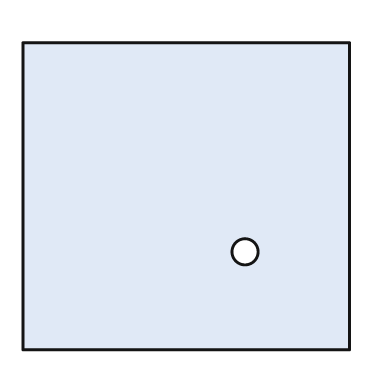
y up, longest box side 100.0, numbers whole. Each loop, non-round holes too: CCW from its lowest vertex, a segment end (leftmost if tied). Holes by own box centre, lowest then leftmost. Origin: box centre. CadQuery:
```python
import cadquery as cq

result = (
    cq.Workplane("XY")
    .moveTo(-50.0, -47.0)
    .lineTo(50.0, -47.0)
    .lineTo(50.0, 47.0)
    .lineTo(-50.0, 47.0)
    .close()
    .moveTo(18.0, -17.0)
    .circle(4.0)
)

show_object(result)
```